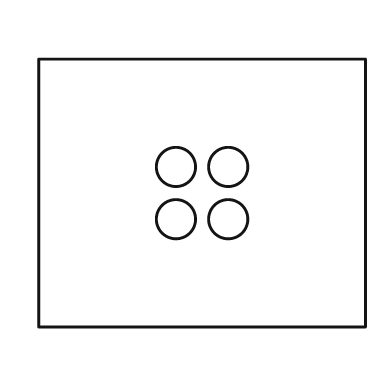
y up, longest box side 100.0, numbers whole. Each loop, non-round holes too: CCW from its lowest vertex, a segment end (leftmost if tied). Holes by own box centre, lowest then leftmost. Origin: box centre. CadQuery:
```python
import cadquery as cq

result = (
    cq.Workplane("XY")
    .moveTo(-50.0, -41.0)
    .lineTo(50.0, -41.0)
    .lineTo(50.0, 41.0)
    .lineTo(-50.0, 41.0)
    .close()
    .moveTo(-8.0, -8.0)
    .circle(6.0)
    .moveTo(8.0, -8.0)
    .circle(6.0)
    .moveTo(-8.0, 8.0)
    .circle(6.0)
    .moveTo(8.0, 8.0)
    .circle(6.0)
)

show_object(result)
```